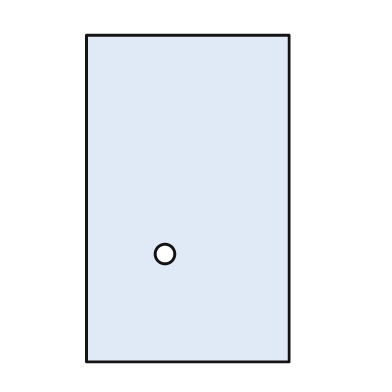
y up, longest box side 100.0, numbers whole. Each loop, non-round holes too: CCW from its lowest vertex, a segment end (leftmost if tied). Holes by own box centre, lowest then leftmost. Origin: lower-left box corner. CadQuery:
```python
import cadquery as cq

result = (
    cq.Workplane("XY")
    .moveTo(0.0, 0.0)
    .lineTo(62.0, 0.0)
    .lineTo(62.0, 100.0)
    .lineTo(0.0, 100.0)
    .close()
    .moveTo(24.0, 33.0)
    .circle(3.0)
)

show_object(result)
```